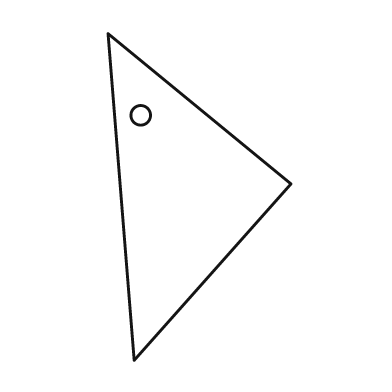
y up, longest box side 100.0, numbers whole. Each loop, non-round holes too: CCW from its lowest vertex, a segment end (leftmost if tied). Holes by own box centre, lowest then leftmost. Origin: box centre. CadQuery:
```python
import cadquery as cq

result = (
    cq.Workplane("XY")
    .moveTo(-20.0, -50.0)
    .lineTo(28.0, 4.0)
    .lineTo(-28.0, 50.0)
    .close()
    .moveTo(-18.0, 25.0)
    .circle(3.0)
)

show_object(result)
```